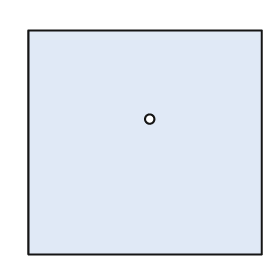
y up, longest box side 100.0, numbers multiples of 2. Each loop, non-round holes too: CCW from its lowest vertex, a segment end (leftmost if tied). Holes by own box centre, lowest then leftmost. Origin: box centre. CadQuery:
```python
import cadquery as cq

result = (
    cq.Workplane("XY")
    .moveTo(-50.0, -48.0)
    .lineTo(50.0, -48.0)
    .lineTo(50.0, 48.0)
    .lineTo(-50.0, 48.0)
    .close()
    .moveTo(2.0, 10.0)
    .circle(2.0)
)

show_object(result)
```